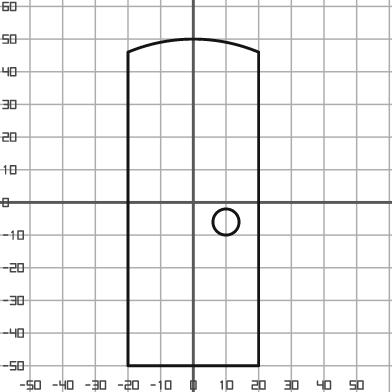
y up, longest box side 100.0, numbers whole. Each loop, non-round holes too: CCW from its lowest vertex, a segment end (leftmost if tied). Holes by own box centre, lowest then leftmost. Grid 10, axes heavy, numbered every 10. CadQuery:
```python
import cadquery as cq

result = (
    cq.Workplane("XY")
    .moveTo(-20.0, -50.0)
    .lineTo(20.0, -50.0)
    .lineTo(20.0, 46.0)
    .threePointArc((0.0, 50.0), (-20.0, 46.0))
    .close()
    .moveTo(10.0, -6.0)
    .circle(4.0)
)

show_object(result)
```